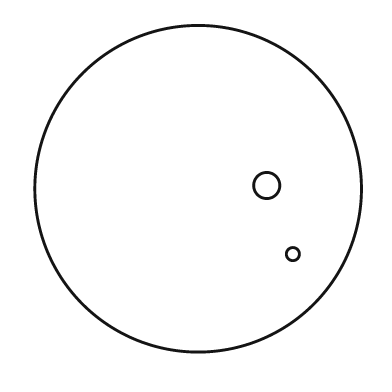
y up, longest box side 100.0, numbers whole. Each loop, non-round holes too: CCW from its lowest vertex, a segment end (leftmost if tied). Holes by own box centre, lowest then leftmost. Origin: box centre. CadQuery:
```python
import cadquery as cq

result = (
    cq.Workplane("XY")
    .moveTo(0.0, 0.0)
    .circle(50.0)
    .moveTo(29.0, -20.0)
    .circle(2.0)
    .moveTo(21.0, 1.0)
    .circle(4.0)
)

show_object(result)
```